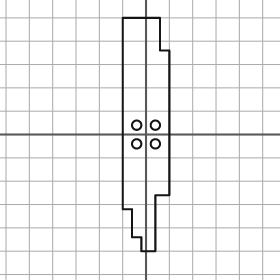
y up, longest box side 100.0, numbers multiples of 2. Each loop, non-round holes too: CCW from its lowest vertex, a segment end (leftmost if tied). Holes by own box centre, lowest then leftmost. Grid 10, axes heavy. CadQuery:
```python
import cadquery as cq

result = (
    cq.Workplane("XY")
    .moveTo(-2.0, -50.0)
    .lineTo(4.0, -50.0)
    .lineTo(4.0, -26.0)
    .lineTo(10.0, -26.0)
    .lineTo(10.0, 36.0)
    .lineTo(6.0, 36.0)
    .lineTo(6.0, 50.0)
    .lineTo(-10.0, 50.0)
    .lineTo(-10.0, -32.0)
    .lineTo(-6.0, -32.0)
    .lineTo(-6.0, -44.0)
    .lineTo(-2.0, -44.0)
    .close()
    .moveTo(-4.0, -4.0)
    .circle(2.0)
    .moveTo(4.0, -4.0)
    .circle(2.0)
    .moveTo(-4.0, 4.0)
    .circle(2.0)
    .moveTo(4.0, 4.0)
    .circle(2.0)
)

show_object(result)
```